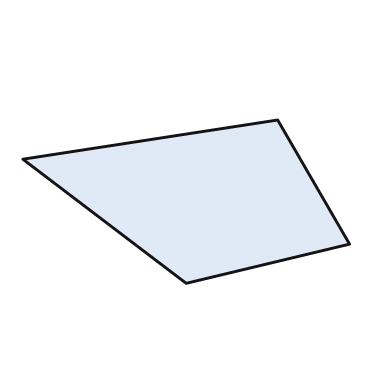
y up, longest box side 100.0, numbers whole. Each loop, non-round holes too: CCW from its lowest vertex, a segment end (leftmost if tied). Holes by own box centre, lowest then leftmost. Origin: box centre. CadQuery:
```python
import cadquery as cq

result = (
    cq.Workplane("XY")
    .moveTo(0.0, -25.0)
    .lineTo(50.0, -13.0)
    .lineTo(28.0, 25.0)
    .lineTo(-50.0, 13.0)
    .close()
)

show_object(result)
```